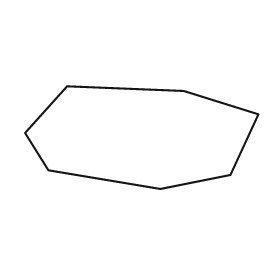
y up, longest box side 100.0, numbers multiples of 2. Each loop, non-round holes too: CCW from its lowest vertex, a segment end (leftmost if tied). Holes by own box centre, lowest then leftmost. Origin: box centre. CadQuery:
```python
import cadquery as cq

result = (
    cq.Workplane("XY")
    .moveTo(8.0, -22.0)
    .lineTo(38.0, -16.0)
    .lineTo(50.0, 10.0)
    .lineTo(18.0, 20.0)
    .lineTo(-32.0, 22.0)
    .lineTo(-50.0, 2.0)
    .lineTo(-40.0, -14.0)
    .close()
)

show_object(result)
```